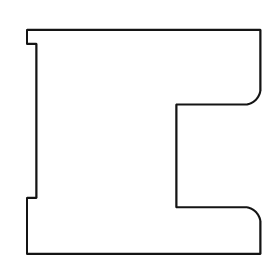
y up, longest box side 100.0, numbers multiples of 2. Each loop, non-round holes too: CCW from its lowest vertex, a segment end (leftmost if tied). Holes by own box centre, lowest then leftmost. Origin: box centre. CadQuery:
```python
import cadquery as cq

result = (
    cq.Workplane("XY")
    .moveTo(-50.0, -48.0)
    .lineTo(50.0, -48.0)
    .lineTo(50.0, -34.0)
    .threePointArc((48.0, -30.0), (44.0, -28.0))
    .lineTo(14.0, -28.0)
    .lineTo(14.0, 16.0)
    .lineTo(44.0, 16.0)
    .threePointArc((48.0, 18.0), (50.0, 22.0))
    .lineTo(50.0, 48.0)
    .lineTo(-50.0, 48.0)
    .lineTo(-50.0, 42.0)
    .lineTo(-46.0, 42.0)
    .lineTo(-46.0, -24.0)
    .lineTo(-50.0, -24.0)
    .close()
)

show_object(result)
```